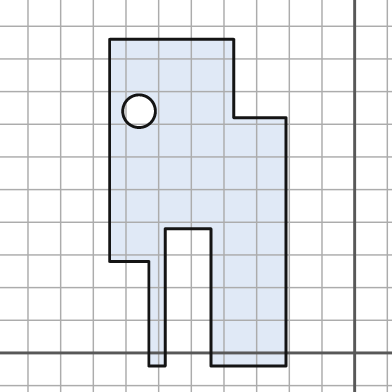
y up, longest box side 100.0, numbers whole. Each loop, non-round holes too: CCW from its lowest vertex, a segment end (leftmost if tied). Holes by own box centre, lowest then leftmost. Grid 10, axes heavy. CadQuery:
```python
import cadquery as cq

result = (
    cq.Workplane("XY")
    .moveTo(-63.0, -4.0)
    .lineTo(-58.0, -4.0)
    .lineTo(-58.0, 38.0)
    .lineTo(-44.0, 38.0)
    .lineTo(-44.0, -4.0)
    .lineTo(-21.0, -4.0)
    .lineTo(-21.0, 72.0)
    .lineTo(-37.0, 72.0)
    .lineTo(-37.0, 96.0)
    .lineTo(-75.0, 96.0)
    .lineTo(-75.0, 28.0)
    .lineTo(-63.0, 28.0)
    .close()
    .moveTo(-66.0, 74.0)
    .circle(5.0)
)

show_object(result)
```